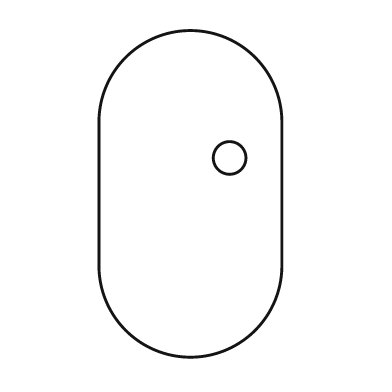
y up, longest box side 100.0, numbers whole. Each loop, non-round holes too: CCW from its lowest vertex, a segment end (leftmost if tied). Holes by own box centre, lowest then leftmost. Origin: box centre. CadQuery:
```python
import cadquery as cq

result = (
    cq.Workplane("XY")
    .moveTo(-28.0, -22.0)
    .threePointArc((0.0, -50.0), (28.0, -22.0))
    .lineTo(28.0, 22.0)
    .threePointArc((0.0, 50.0), (-28.0, 22.0))
    .close()
    .moveTo(12.0, 11.0)
    .circle(5.0)
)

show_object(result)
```